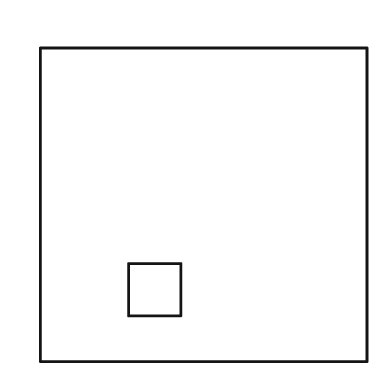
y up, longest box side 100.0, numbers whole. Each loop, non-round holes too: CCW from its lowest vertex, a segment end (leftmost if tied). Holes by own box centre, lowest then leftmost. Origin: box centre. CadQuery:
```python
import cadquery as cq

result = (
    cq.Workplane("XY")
    .moveTo(-50.0, -48.0)
    .lineTo(50.0, -48.0)
    .lineTo(50.0, 48.0)
    .lineTo(-50.0, 48.0)
    .close()
    .moveTo(-23.0, -34.0)
    .lineTo(-7.0, -34.0)
    .lineTo(-7.0, -18.0)
    .lineTo(-23.0, -18.0)
    .close()
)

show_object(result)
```